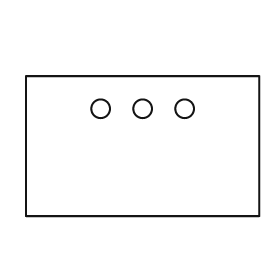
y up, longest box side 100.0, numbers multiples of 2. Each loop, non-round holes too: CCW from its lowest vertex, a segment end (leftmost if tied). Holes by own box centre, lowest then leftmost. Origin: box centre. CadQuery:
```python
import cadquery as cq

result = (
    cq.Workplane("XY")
    .moveTo(-50.0, -30.0)
    .lineTo(50.0, -30.0)
    .lineTo(50.0, 30.0)
    .lineTo(-50.0, 30.0)
    .close()
    .moveTo(-18.0, 16.0)
    .circle(4.0)
    .moveTo(0.0, 16.0)
    .circle(4.0)
    .moveTo(18.0, 16.0)
    .circle(4.0)
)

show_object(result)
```